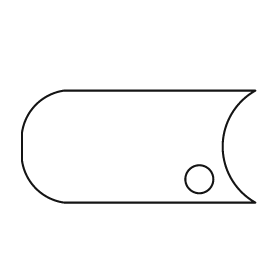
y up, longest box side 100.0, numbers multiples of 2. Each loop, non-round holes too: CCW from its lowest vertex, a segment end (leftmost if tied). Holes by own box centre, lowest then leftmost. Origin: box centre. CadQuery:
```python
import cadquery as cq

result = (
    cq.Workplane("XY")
    .moveTo(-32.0, -24.0)
    .lineTo(50.0, -24.0)
    .threePointArc((36.0, 0.0), (50.0, 24.0))
    .lineTo(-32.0, 24.0)
    .threePointArc((-44.0, 18.0), (-50.0, 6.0))
    .lineTo(-50.0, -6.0)
    .threePointArc((-44.0, -18.0), (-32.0, -24.0))
    .close()
    .moveTo(26.0, -14.0)
    .circle(6.0)
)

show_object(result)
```